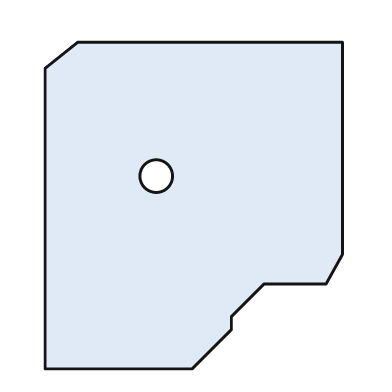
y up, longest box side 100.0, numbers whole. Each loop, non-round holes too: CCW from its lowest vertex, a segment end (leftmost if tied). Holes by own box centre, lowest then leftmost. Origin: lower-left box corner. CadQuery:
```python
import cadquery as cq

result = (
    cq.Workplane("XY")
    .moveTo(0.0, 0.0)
    .lineTo(45.0, 0.0)
    .lineTo(57.0, 12.0)
    .lineTo(57.0, 16.0)
    .lineTo(67.0, 26.0)
    .lineTo(86.0, 26.0)
    .lineTo(91.0, 35.0)
    .lineTo(91.0, 100.0)
    .lineTo(10.0, 100.0)
    .lineTo(0.0, 92.0)
    .close()
    .moveTo(34.0, 59.0)
    .circle(5.0)
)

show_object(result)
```